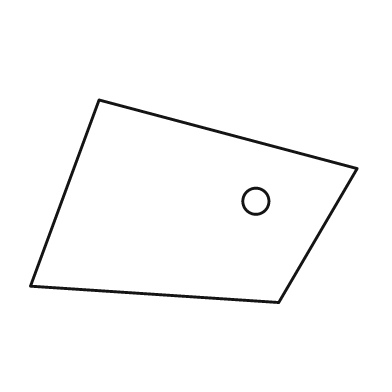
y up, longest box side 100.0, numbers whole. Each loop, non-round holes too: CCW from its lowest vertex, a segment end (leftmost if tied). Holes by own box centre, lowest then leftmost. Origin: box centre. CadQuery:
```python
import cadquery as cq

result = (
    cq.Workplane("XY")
    .moveTo(26.0, -31.0)
    .lineTo(50.0, 10.0)
    .lineTo(-29.0, 31.0)
    .lineTo(-50.0, -26.0)
    .close()
    .moveTo(19.0, 0.0)
    .circle(4.0)
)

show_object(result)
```